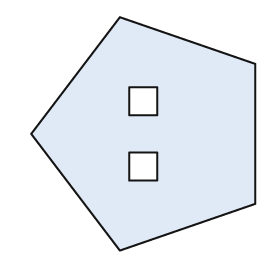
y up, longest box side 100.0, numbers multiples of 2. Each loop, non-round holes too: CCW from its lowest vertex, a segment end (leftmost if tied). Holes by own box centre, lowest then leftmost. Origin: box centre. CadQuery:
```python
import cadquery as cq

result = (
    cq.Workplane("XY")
    .moveTo(-10.0, -50.0)
    .lineTo(48.0, -30.0)
    .lineTo(48.0, 30.0)
    .lineTo(-10.0, 50.0)
    .lineTo(-48.0, 0.0)
    .close()
    .moveTo(-6.0, -20.0)
    .lineTo(6.0, -20.0)
    .lineTo(6.0, -8.0)
    .lineTo(-6.0, -8.0)
    .close()
    .moveTo(-6.0, 8.0)
    .lineTo(6.0, 8.0)
    .lineTo(6.0, 20.0)
    .lineTo(-6.0, 20.0)
    .close()
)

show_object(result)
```